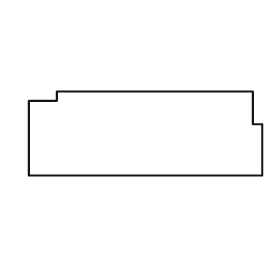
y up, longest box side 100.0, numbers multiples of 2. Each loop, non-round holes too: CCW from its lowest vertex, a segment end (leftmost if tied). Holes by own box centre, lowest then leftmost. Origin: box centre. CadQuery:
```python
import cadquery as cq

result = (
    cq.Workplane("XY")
    .moveTo(-50.0, -18.0)
    .lineTo(50.0, -18.0)
    .lineTo(50.0, 4.0)
    .lineTo(46.0, 4.0)
    .lineTo(46.0, 18.0)
    .lineTo(-38.0, 18.0)
    .lineTo(-38.0, 14.0)
    .lineTo(-50.0, 14.0)
    .close()
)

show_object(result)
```